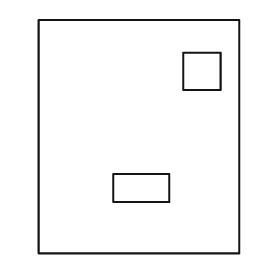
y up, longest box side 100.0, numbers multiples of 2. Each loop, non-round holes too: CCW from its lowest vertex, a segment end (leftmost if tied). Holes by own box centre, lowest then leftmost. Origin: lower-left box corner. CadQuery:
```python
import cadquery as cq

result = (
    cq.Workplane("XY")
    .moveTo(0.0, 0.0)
    .lineTo(86.0, 0.0)
    .lineTo(86.0, 100.0)
    .lineTo(0.0, 100.0)
    .close()
    .moveTo(32.0, 22.0)
    .lineTo(56.0, 22.0)
    .lineTo(56.0, 34.0)
    .lineTo(32.0, 34.0)
    .close()
    .moveTo(62.0, 70.0)
    .lineTo(78.0, 70.0)
    .lineTo(78.0, 86.0)
    .lineTo(62.0, 86.0)
    .close()
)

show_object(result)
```